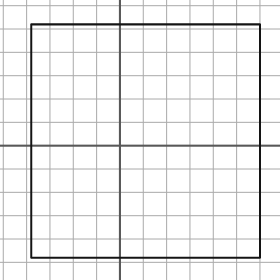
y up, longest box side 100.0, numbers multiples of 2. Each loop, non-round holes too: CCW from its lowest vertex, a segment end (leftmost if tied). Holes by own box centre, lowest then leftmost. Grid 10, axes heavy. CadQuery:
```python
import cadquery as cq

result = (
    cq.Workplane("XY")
    .moveTo(-38.0, -48.0)
    .lineTo(60.0, -48.0)
    .lineTo(60.0, 52.0)
    .lineTo(-38.0, 52.0)
    .close()
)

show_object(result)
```